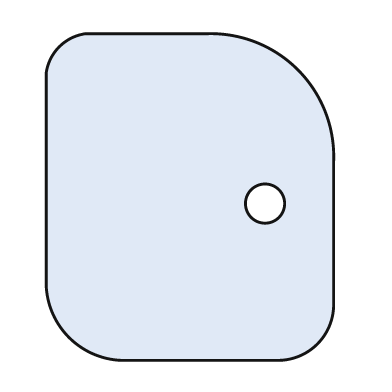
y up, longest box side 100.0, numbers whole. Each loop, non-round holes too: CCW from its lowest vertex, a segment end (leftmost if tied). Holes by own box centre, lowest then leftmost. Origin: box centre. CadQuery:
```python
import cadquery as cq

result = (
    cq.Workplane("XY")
    .moveTo(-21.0, -50.0)
    .lineTo(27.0, -50.0)
    .threePointArc((39.0, -45.0), (44.0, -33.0))
    .lineTo(44.0, 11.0)
    .threePointArc((33.0, 39.0), (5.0, 50.0))
    .lineTo(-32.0, 50.0)
    .threePointArc((-40.0, 46.0), (-44.0, 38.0))
    .lineTo(-44.0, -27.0)
    .threePointArc((-37.0, -43.0), (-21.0, -50.0))
    .close()
    .moveTo(23.0, -2.0)
    .circle(6.0)
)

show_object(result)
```